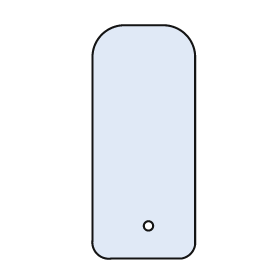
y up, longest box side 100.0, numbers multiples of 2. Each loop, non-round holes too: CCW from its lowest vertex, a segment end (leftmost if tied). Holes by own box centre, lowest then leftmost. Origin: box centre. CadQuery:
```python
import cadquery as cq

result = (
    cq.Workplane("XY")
    .moveTo(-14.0, -50.0)
    .lineTo(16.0, -50.0)
    .threePointArc((20.0, -48.0), (22.0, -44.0))
    .lineTo(22.0, 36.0)
    .threePointArc((18.0, 46.0), (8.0, 50.0))
    .lineTo(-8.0, 50.0)
    .threePointArc((-18.0, 46.0), (-22.0, 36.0))
    .lineTo(-22.0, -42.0)
    .threePointArc((-20.0, -48.0), (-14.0, -50.0))
    .close()
    .moveTo(2.0, -36.0)
    .circle(2.0)
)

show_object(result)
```